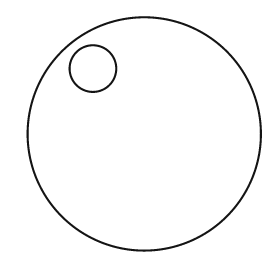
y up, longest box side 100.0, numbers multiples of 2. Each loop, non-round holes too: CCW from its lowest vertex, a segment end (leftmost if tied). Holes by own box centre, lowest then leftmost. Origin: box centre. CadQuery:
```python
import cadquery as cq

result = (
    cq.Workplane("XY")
    .moveTo(0.0, 0.0)
    .circle(50.0)
    .moveTo(-22.0, 28.0)
    .circle(10.0)
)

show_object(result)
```